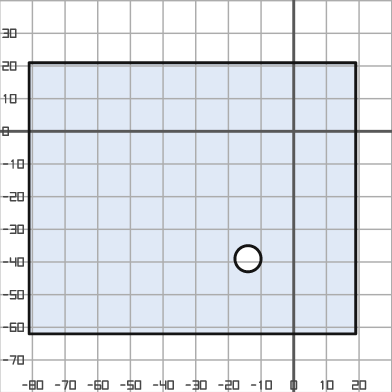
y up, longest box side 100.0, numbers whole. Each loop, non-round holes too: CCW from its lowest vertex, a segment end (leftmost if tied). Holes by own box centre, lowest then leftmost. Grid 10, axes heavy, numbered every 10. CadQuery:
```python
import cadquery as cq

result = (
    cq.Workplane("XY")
    .moveTo(-81.0, -62.0)
    .lineTo(19.0, -62.0)
    .lineTo(19.0, 21.0)
    .lineTo(-81.0, 21.0)
    .close()
    .moveTo(-14.0, -39.0)
    .circle(4.0)
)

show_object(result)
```